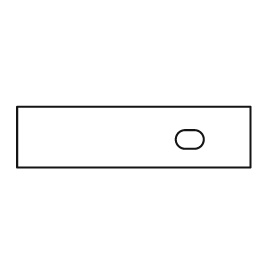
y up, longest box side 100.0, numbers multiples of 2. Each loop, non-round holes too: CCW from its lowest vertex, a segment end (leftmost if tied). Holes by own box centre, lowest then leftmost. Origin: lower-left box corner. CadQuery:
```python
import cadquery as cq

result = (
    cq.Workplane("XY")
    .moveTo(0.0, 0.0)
    .lineTo(100.0, 0.0)
    .lineTo(100.0, 26.0)
    .lineTo(0.0, 26.0)
    .close()
    .moveTo(72.0, 8.0)
    .lineTo(76.0, 8.0)
    .threePointArc((80.0, 12.0), (76.0, 16.0))
    .lineTo(72.0, 16.0)
    .threePointArc((68.0, 12.0), (72.0, 8.0))
    .close()
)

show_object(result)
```